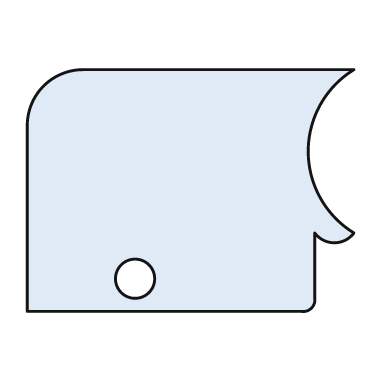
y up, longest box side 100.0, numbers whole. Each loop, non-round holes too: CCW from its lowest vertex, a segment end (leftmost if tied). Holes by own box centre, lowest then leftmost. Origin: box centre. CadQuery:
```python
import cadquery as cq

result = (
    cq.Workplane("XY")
    .moveTo(-50.0, -37.0)
    .lineTo(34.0, -37.0)
    .threePointArc((37.0, -36.0), (38.0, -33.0))
    .lineTo(38.0, -13.0)
    .threePointArc((44.0, -16.0), (50.0, -13.0))
    .threePointArc((36.0, 12.0), (50.0, 37.0))
    .lineTo(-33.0, 37.0)
    .threePointArc((-45.0, 32.0), (-50.0, 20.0))
    .close()
    .moveTo(-17.0, -27.0)
    .circle(6.0)
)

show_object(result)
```